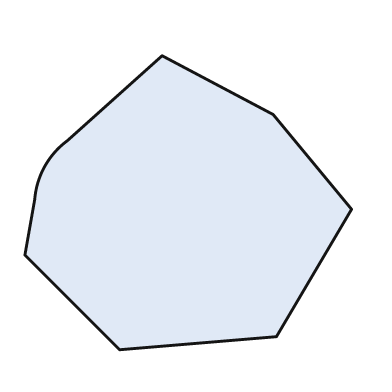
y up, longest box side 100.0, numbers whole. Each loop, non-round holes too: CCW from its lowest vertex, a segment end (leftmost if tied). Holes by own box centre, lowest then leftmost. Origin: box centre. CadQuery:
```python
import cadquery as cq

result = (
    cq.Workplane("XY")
    .moveTo(-21.0, -45.0)
    .lineTo(27.0, -41.0)
    .lineTo(50.0, -2.0)
    .lineTo(26.0, 27.0)
    .lineTo(-8.0, 45.0)
    .lineTo(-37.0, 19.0)
    .threePointArc((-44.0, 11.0), (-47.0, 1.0))
    .lineTo(-50.0, -16.0)
    .close()
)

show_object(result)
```